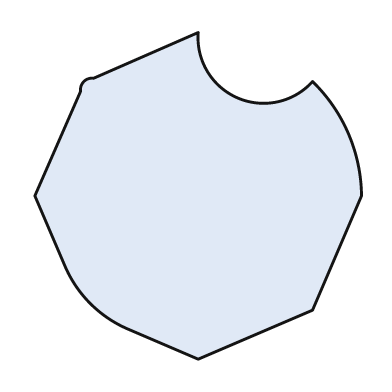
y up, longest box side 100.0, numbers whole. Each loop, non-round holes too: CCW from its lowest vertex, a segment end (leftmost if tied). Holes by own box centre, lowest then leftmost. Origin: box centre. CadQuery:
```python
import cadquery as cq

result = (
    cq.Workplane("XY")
    .moveTo(0.0, -50.0)
    .lineTo(35.0, -35.0)
    .lineTo(50.0, 0.0)
    .threePointArc((46.0, 19.0), (35.0, 35.0))
    .threePointArc((12.0, 30.0), (0.0, 50.0))
    .lineTo(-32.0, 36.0)
    .threePointArc((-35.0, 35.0), (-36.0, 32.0))
    .lineTo(-50.0, 0.0)
    .lineTo(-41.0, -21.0)
    .threePointArc((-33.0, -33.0), (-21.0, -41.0))
    .close()
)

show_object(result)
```